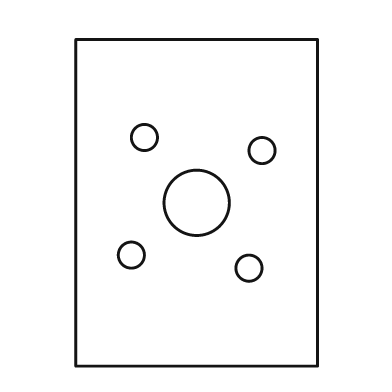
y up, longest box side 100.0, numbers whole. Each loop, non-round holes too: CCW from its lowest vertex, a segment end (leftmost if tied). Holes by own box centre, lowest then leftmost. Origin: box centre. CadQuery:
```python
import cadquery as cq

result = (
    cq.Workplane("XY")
    .moveTo(-37.0, -50.0)
    .lineTo(37.0, -50.0)
    .lineTo(37.0, 50.0)
    .lineTo(-37.0, 50.0)
    .close()
    .moveTo(16.0, -20.0)
    .circle(4.0)
    .moveTo(-20.0, -16.0)
    .circle(4.0)
    .moveTo(0.0, 0.0)
    .circle(10.0)
    .moveTo(20.0, 16.0)
    .circle(4.0)
    .moveTo(-16.0, 20.0)
    .circle(4.0)
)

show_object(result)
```